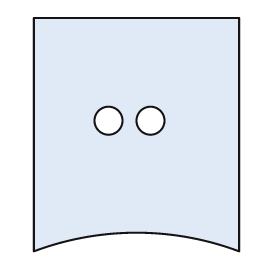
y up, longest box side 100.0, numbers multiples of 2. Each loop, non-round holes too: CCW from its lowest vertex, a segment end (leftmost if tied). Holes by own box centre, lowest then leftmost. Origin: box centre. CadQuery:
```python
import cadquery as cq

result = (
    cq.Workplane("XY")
    .moveTo(-44.0, -50.0)
    .threePointArc((0.0, -42.0), (44.0, -50.0))
    .lineTo(44.0, 50.0)
    .lineTo(-44.0, 50.0)
    .close()
    .moveTo(-12.0, 6.0)
    .circle(6.0)
    .moveTo(6.0, 6.0)
    .circle(6.0)
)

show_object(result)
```